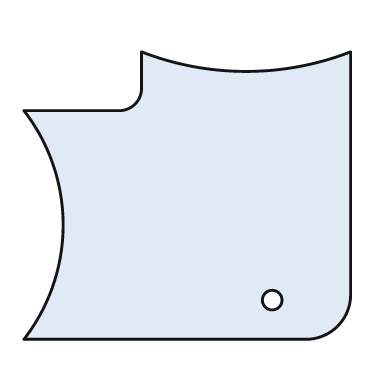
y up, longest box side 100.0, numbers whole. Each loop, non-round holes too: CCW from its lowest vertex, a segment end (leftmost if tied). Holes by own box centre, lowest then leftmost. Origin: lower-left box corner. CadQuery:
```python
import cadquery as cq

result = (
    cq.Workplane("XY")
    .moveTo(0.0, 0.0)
    .lineTo(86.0, 0.0)
    .threePointArc((96.0, 4.0), (100.0, 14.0))
    .lineTo(100.0, 88.0)
    .threePointArc((68.0, 82.0), (36.0, 88.0))
    .lineTo(36.0, 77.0)
    .threePointArc((34.0, 72.0), (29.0, 70.0))
    .lineTo(0.0, 70.0)
    .threePointArc((12.0, 35.0), (0.0, 0.0))
    .close()
    .moveTo(76.0, 12.0)
    .circle(3.0)
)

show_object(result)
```